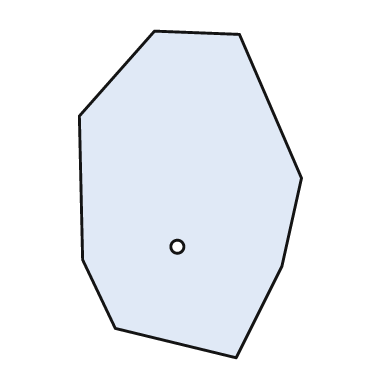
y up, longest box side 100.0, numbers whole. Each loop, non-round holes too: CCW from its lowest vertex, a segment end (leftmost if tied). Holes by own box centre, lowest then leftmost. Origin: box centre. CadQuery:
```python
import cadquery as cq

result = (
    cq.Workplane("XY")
    .moveTo(14.0, -50.0)
    .lineTo(28.0, -22.0)
    .lineTo(34.0, 5.0)
    .lineTo(15.0, 49.0)
    .lineTo(-11.0, 50.0)
    .lineTo(-34.0, 24.0)
    .lineTo(-33.0, -20.0)
    .lineTo(-23.0, -41.0)
    .close()
    .moveTo(-4.0, -16.0)
    .circle(2.0)
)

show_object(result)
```